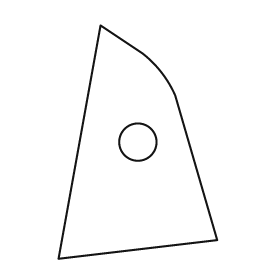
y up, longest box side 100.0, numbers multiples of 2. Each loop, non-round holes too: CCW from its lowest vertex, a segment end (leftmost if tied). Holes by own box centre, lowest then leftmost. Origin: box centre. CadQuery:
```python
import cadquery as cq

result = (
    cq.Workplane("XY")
    .moveTo(-34.0, -50.0)
    .lineTo(34.0, -42.0)
    .lineTo(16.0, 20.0)
    .threePointArc((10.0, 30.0), (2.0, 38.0))
    .lineTo(-16.0, 50.0)
    .close()
    .moveTo(0.0, 0.0)
    .circle(8.0)
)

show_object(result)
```